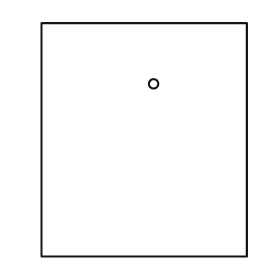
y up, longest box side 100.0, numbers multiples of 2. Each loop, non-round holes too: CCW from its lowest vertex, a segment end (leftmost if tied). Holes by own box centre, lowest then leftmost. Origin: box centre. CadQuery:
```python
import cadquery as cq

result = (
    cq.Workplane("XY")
    .moveTo(-44.0, -50.0)
    .lineTo(44.0, -50.0)
    .lineTo(44.0, 50.0)
    .lineTo(-44.0, 50.0)
    .close()
    .moveTo(4.0, 24.0)
    .circle(2.0)
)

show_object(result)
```